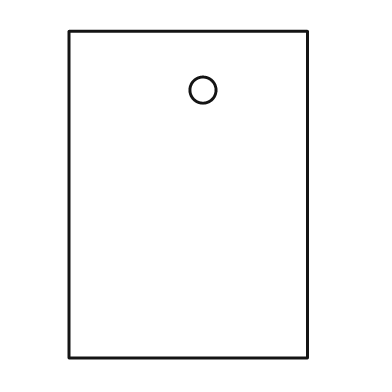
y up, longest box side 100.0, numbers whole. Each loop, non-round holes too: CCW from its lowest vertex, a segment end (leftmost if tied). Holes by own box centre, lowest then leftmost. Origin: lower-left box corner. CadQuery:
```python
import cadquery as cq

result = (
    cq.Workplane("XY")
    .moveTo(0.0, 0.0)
    .lineTo(73.0, 0.0)
    .lineTo(73.0, 100.0)
    .lineTo(0.0, 100.0)
    .close()
    .moveTo(41.0, 82.0)
    .circle(4.0)
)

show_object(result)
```